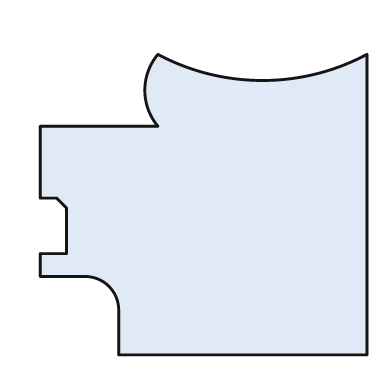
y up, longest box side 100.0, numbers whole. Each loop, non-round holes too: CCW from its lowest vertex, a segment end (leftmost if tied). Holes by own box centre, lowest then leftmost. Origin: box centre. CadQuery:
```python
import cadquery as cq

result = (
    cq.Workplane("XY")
    .moveTo(-26.0, -46.0)
    .lineTo(50.0, -46.0)
    .lineTo(50.0, 46.0)
    .threePointArc((18.0, 38.0), (-14.0, 46.0))
    .threePointArc((-18.0, 35.0), (-14.0, 24.0))
    .lineTo(-50.0, 24.0)
    .lineTo(-50.0, 2.0)
    .lineTo(-45.0, 2.0)
    .lineTo(-42.0, -1.0)
    .lineTo(-42.0, -15.0)
    .lineTo(-50.0, -15.0)
    .lineTo(-50.0, -22.0)
    .lineTo(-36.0, -22.0)
    .threePointArc((-29.0, -25.0), (-26.0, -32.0))
    .close()
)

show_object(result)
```